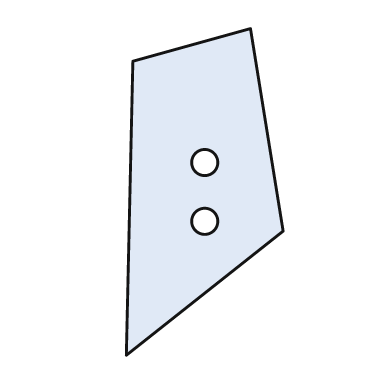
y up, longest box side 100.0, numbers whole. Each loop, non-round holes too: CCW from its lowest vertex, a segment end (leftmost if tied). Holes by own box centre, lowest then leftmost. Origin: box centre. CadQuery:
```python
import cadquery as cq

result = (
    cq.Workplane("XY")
    .moveTo(-24.0, -50.0)
    .lineTo(24.0, -12.0)
    .lineTo(14.0, 50.0)
    .lineTo(-22.0, 40.0)
    .close()
    .moveTo(0.0, -9.0)
    .circle(4.0)
    .moveTo(0.0, 9.0)
    .circle(4.0)
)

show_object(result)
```